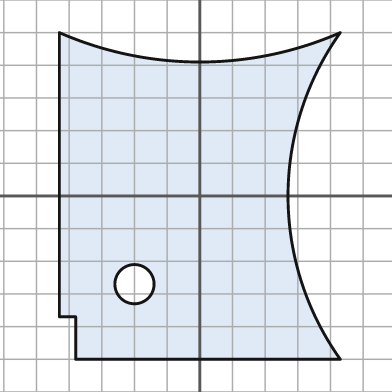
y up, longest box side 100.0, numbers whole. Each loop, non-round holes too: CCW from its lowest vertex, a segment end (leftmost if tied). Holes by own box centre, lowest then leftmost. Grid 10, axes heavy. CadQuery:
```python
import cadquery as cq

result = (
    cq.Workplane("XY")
    .moveTo(-38.0, -50.0)
    .lineTo(43.0, -50.0)
    .threePointArc((27.0, 0.0), (43.0, 50.0))
    .threePointArc((0.0, 41.0), (-43.0, 50.0))
    .lineTo(-43.0, -37.0)
    .lineTo(-38.0, -37.0)
    .close()
    .moveTo(-20.0, -27.0)
    .circle(6.0)
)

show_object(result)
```